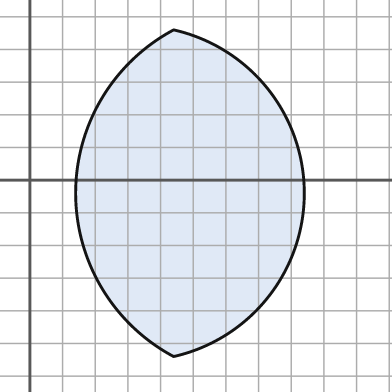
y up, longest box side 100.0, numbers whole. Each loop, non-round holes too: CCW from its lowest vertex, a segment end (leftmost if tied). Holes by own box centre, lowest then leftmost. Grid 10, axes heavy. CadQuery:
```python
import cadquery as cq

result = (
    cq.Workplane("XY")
    .moveTo(44.0, -54.0)
    .threePointArc((84.0, -4.0), (44.0, 46.0))
    .threePointArc((14.0, -4.0), (44.0, -54.0))
    .close()
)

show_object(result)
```